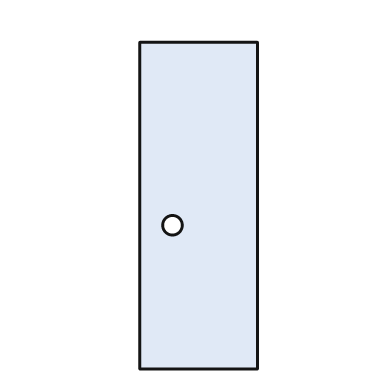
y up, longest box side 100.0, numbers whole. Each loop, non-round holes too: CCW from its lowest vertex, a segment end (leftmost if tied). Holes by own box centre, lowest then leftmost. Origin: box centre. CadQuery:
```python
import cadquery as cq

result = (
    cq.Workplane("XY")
    .moveTo(-18.0, -50.0)
    .lineTo(18.0, -50.0)
    .lineTo(18.0, 50.0)
    .lineTo(-18.0, 50.0)
    .close()
    .moveTo(-8.0, -6.0)
    .circle(3.0)
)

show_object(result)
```